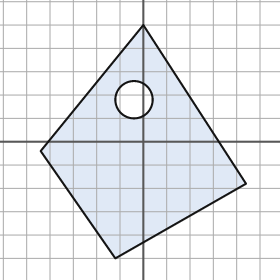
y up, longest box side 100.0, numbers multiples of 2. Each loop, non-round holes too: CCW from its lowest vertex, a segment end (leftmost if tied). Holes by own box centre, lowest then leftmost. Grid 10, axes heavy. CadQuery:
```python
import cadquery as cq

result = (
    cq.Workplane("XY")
    .moveTo(-12.0, -50.0)
    .lineTo(44.0, -18.0)
    .lineTo(0.0, 50.0)
    .lineTo(-44.0, -4.0)
    .close()
    .moveTo(-4.0, 18.0)
    .circle(8.0)
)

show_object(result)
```